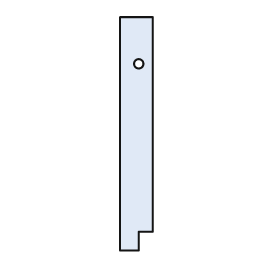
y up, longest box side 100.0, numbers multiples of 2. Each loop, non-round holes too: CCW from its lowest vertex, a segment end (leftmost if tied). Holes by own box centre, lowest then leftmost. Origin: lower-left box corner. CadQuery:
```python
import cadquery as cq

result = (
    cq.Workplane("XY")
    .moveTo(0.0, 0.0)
    .lineTo(8.0, 0.0)
    .lineTo(8.0, 8.0)
    .lineTo(14.0, 8.0)
    .lineTo(14.0, 100.0)
    .lineTo(0.0, 100.0)
    .close()
    .moveTo(8.0, 80.0)
    .circle(2.0)
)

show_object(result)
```